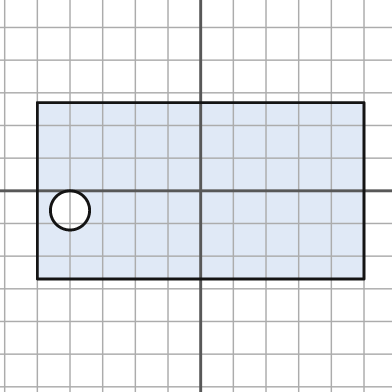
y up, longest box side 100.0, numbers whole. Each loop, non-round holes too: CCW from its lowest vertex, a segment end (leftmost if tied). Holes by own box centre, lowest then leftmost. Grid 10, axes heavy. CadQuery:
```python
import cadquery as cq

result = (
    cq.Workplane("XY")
    .moveTo(-50.0, -27.0)
    .lineTo(50.0, -27.0)
    .lineTo(50.0, 27.0)
    .lineTo(-50.0, 27.0)
    .close()
    .moveTo(-40.0, -6.0)
    .circle(6.0)
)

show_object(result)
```